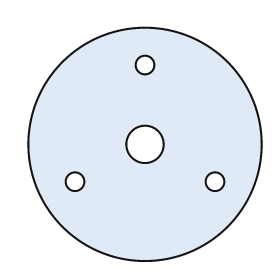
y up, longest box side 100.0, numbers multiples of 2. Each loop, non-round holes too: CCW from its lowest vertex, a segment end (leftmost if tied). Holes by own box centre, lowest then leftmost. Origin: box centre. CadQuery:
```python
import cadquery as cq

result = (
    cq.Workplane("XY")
    .moveTo(0.0, 0.0)
    .circle(50.0)
    .moveTo(-30.0, -16.0)
    .circle(4.0)
    .moveTo(30.0, -16.0)
    .circle(4.0)
    .moveTo(0.0, 0.0)
    .circle(8.0)
    .moveTo(0.0, 34.0)
    .circle(4.0)
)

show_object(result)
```